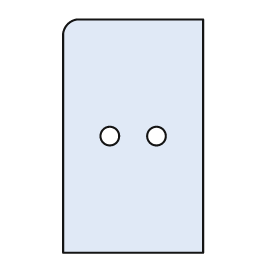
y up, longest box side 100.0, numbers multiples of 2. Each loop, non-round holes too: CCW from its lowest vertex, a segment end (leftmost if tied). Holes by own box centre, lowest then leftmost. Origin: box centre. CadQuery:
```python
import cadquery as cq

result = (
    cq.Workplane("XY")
    .moveTo(-30.0, -50.0)
    .lineTo(30.0, -50.0)
    .lineTo(30.0, 50.0)
    .lineTo(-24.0, 50.0)
    .threePointArc((-28.0, 48.0), (-30.0, 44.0))
    .close()
    .moveTo(-10.0, 0.0)
    .circle(4.0)
    .moveTo(10.0, 0.0)
    .circle(4.0)
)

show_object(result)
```